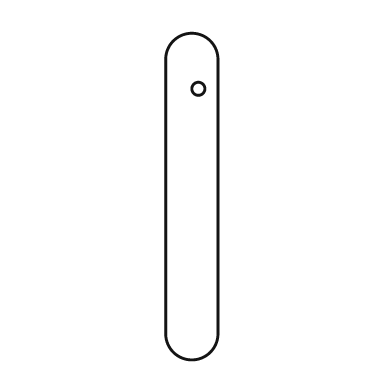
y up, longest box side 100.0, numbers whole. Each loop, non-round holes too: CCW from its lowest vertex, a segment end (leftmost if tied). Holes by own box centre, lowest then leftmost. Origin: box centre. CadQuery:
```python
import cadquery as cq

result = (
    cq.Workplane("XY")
    .moveTo(-8.0, -42.0)
    .threePointArc((0.0, -50.0), (8.0, -42.0))
    .lineTo(8.0, 42.0)
    .threePointArc((0.0, 50.0), (-8.0, 42.0))
    .close()
    .moveTo(2.0, 33.0)
    .circle(2.0)
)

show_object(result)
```